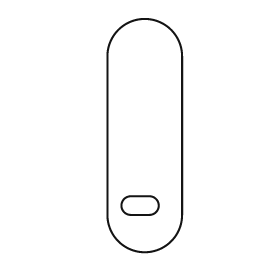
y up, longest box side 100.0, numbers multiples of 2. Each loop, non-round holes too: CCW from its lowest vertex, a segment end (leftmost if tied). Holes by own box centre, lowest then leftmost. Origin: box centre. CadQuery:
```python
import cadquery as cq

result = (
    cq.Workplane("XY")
    .moveTo(-16.0, -34.0)
    .threePointArc((0.0, -50.0), (16.0, -34.0))
    .lineTo(16.0, 34.0)
    .threePointArc((0.0, 50.0), (-16.0, 34.0))
    .close()
    .moveTo(-6.0, -34.0)
    .lineTo(2.0, -34.0)
    .threePointArc((6.0, -30.0), (2.0, -26.0))
    .lineTo(-6.0, -26.0)
    .threePointArc((-10.0, -30.0), (-6.0, -34.0))
    .close()
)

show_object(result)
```